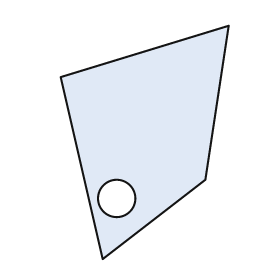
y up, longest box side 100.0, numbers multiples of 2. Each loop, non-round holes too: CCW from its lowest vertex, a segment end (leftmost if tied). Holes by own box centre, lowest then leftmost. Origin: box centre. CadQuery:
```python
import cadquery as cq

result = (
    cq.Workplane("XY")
    .moveTo(-18.0, -50.0)
    .lineTo(26.0, -16.0)
    .lineTo(36.0, 50.0)
    .lineTo(-36.0, 28.0)
    .close()
    .moveTo(-12.0, -24.0)
    .circle(8.0)
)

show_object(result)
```